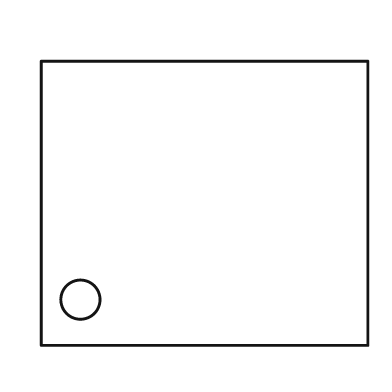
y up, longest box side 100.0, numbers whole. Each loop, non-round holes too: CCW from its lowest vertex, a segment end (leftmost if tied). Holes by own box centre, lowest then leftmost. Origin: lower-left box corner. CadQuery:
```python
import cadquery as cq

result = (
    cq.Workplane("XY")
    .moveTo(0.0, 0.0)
    .lineTo(100.0, 0.0)
    .lineTo(100.0, 87.0)
    .lineTo(0.0, 87.0)
    .close()
    .moveTo(12.0, 14.0)
    .circle(6.0)
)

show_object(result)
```